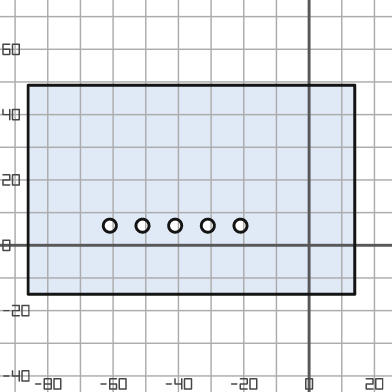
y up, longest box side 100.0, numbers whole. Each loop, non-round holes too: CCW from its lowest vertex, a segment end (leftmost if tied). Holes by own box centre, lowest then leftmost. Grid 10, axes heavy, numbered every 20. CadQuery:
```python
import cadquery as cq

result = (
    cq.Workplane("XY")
    .moveTo(-86.0, -15.0)
    .lineTo(14.0, -15.0)
    .lineTo(14.0, 49.0)
    .lineTo(-86.0, 49.0)
    .close()
    .moveTo(-61.0, 6.0)
    .circle(2.0)
    .moveTo(-51.0, 6.0)
    .circle(2.0)
    .moveTo(-41.0, 6.0)
    .circle(2.0)
    .moveTo(-31.0, 6.0)
    .circle(2.0)
    .moveTo(-21.0, 6.0)
    .circle(2.0)
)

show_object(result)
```